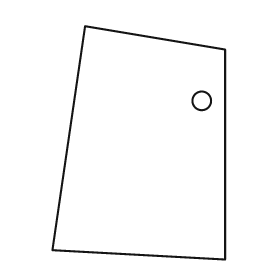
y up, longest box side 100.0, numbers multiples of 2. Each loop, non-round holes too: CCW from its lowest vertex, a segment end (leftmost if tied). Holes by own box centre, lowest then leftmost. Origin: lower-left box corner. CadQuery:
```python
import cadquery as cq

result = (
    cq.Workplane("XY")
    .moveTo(74.0, 0.0)
    .lineTo(74.0, 90.0)
    .lineTo(14.0, 100.0)
    .lineTo(0.0, 4.0)
    .close()
    .moveTo(64.0, 68.0)
    .circle(4.0)
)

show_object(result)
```